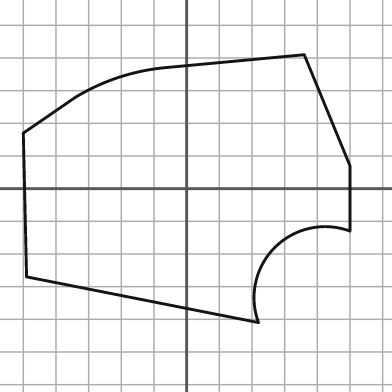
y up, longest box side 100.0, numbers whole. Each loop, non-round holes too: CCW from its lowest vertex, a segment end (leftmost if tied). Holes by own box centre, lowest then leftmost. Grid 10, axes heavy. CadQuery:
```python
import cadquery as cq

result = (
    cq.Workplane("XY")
    .moveTo(22.0, -41.0)
    .threePointArc((27.0, -18.0), (50.0, -13.0))
    .lineTo(50.0, 7.0)
    .lineTo(36.0, 41.0)
    .lineTo(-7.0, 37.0)
    .threePointArc((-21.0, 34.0), (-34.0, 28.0))
    .lineTo(-50.0, 17.0)
    .lineTo(-49.0, -27.0)
    .close()
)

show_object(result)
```